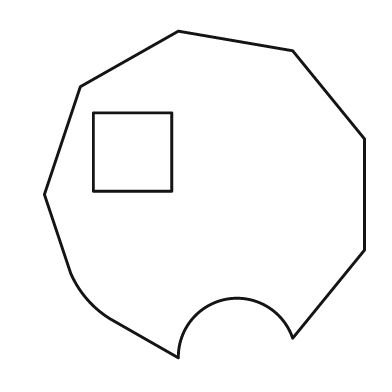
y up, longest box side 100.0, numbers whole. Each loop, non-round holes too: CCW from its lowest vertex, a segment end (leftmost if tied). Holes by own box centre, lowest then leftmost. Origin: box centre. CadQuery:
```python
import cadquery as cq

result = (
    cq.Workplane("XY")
    .moveTo(-8.0, -50.0)
    .threePointArc((7.0, -32.0), (27.0, -44.0))
    .lineTo(49.0, -17.0)
    .lineTo(49.0, 17.0)
    .lineTo(27.0, 44.0)
    .lineTo(-8.0, 50.0)
    .lineTo(-38.0, 33.0)
    .lineTo(-49.0, 0.0)
    .lineTo(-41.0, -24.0)
    .threePointArc((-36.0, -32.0), (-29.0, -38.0))
    .close()
    .moveTo(-34.0, 1.0)
    .lineTo(-10.0, 1.0)
    .lineTo(-10.0, 25.0)
    .lineTo(-34.0, 25.0)
    .close()
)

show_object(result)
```